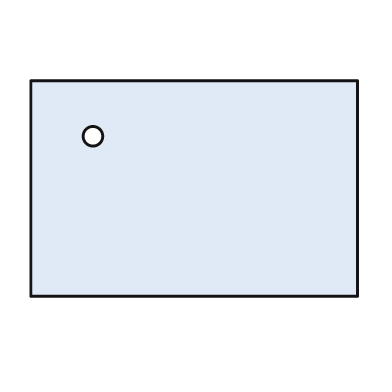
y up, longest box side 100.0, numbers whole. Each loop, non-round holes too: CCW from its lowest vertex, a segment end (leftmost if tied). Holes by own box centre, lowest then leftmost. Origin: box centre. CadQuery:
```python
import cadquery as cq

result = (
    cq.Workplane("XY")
    .moveTo(-50.0, -33.0)
    .lineTo(50.0, -33.0)
    .lineTo(50.0, 33.0)
    .lineTo(-50.0, 33.0)
    .close()
    .moveTo(-31.0, 16.0)
    .circle(3.0)
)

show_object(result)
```